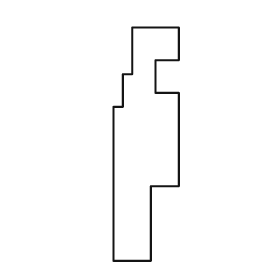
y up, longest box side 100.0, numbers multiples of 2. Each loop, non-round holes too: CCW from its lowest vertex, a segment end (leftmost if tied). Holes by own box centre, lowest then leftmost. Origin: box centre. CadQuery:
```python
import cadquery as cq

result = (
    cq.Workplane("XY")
    .moveTo(-14.0, -50.0)
    .lineTo(2.0, -50.0)
    .lineTo(2.0, -18.0)
    .lineTo(14.0, -18.0)
    .lineTo(14.0, 22.0)
    .lineTo(4.0, 22.0)
    .lineTo(4.0, 36.0)
    .lineTo(14.0, 36.0)
    .lineTo(14.0, 50.0)
    .lineTo(-6.0, 50.0)
    .lineTo(-6.0, 30.0)
    .lineTo(-10.0, 30.0)
    .lineTo(-10.0, 16.0)
    .lineTo(-14.0, 16.0)
    .close()
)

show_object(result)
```